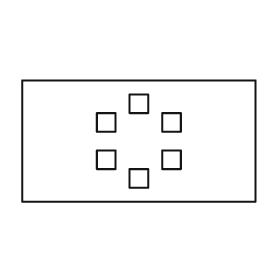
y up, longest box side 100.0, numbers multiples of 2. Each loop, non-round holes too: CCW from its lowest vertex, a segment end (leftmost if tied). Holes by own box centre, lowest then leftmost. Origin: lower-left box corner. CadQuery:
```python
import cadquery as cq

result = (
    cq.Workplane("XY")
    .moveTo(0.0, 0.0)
    .lineTo(100.0, 0.0)
    .lineTo(100.0, 52.0)
    .lineTo(0.0, 52.0)
    .close()
    .moveTo(46.0, 6.0)
    .lineTo(54.0, 6.0)
    .lineTo(54.0, 14.0)
    .lineTo(46.0, 14.0)
    .close()
    .moveTo(32.0, 14.0)
    .lineTo(40.0, 14.0)
    .lineTo(40.0, 22.0)
    .lineTo(32.0, 22.0)
    .close()
    .moveTo(60.0, 14.0)
    .lineTo(68.0, 14.0)
    .lineTo(68.0, 22.0)
    .lineTo(60.0, 22.0)
    .close()
    .moveTo(32.0, 30.0)
    .lineTo(40.0, 30.0)
    .lineTo(40.0, 38.0)
    .lineTo(32.0, 38.0)
    .close()
    .moveTo(60.0, 30.0)
    .lineTo(68.0, 30.0)
    .lineTo(68.0, 38.0)
    .lineTo(60.0, 38.0)
    .close()
    .moveTo(46.0, 38.0)
    .lineTo(54.0, 38.0)
    .lineTo(54.0, 46.0)
    .lineTo(46.0, 46.0)
    .close()
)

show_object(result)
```